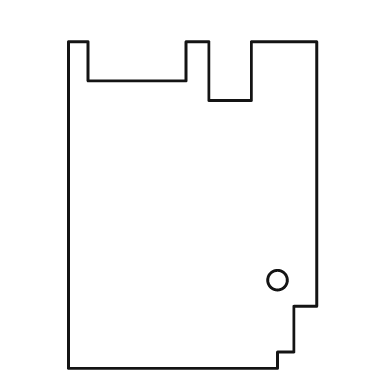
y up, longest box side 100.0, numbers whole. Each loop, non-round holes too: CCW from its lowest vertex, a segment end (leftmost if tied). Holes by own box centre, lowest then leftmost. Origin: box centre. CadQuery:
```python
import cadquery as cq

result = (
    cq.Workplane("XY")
    .moveTo(-38.0, -50.0)
    .lineTo(26.0, -50.0)
    .lineTo(26.0, -45.0)
    .lineTo(31.0, -45.0)
    .lineTo(31.0, -31.0)
    .lineTo(38.0, -31.0)
    .lineTo(38.0, 50.0)
    .lineTo(18.0, 50.0)
    .lineTo(18.0, 32.0)
    .lineTo(5.0, 32.0)
    .lineTo(5.0, 50.0)
    .lineTo(-2.0, 50.0)
    .lineTo(-2.0, 38.0)
    .lineTo(-32.0, 38.0)
    .lineTo(-32.0, 50.0)
    .lineTo(-38.0, 50.0)
    .close()
    .moveTo(26.0, -23.0)
    .circle(3.0)
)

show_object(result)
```